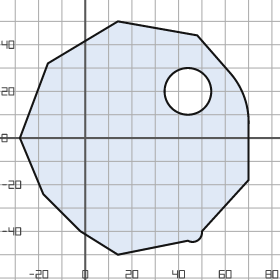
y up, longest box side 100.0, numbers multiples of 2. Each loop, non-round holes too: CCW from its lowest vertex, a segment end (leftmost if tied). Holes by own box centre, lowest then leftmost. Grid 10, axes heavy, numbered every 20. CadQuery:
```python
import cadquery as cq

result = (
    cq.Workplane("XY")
    .moveTo(14.0, -50.0)
    .lineTo(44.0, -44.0)
    .threePointArc((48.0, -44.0), (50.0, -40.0))
    .lineTo(70.0, -18.0)
    .lineTo(70.0, 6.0)
    .threePointArc((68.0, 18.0), (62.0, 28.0))
    .lineTo(48.0, 44.0)
    .lineTo(14.0, 50.0)
    .lineTo(-16.0, 32.0)
    .lineTo(-28.0, 0.0)
    .lineTo(-18.0, -24.0)
    .lineTo(-2.0, -40.0)
    .close()
    .moveTo(44.0, 20.0)
    .circle(10.0)
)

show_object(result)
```